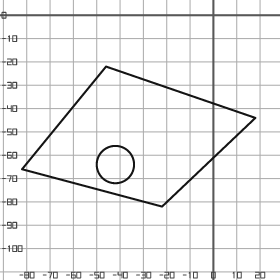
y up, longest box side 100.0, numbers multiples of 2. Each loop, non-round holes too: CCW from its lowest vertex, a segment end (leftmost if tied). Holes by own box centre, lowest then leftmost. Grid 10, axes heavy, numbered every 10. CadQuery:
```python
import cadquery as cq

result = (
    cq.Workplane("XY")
    .moveTo(-22.0, -82.0)
    .lineTo(18.0, -44.0)
    .lineTo(-46.0, -22.0)
    .lineTo(-82.0, -66.0)
    .close()
    .moveTo(-42.0, -64.0)
    .circle(8.0)
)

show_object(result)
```